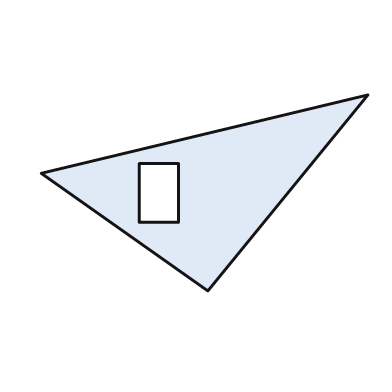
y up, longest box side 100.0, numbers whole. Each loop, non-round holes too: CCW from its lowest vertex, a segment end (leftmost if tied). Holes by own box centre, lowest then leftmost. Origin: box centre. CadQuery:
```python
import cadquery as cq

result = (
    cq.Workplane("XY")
    .moveTo(1.0, -30.0)
    .lineTo(50.0, 30.0)
    .lineTo(-50.0, 6.0)
    .close()
    .moveTo(-20.0, -9.0)
    .lineTo(-8.0, -9.0)
    .lineTo(-8.0, 9.0)
    .lineTo(-20.0, 9.0)
    .close()
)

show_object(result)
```